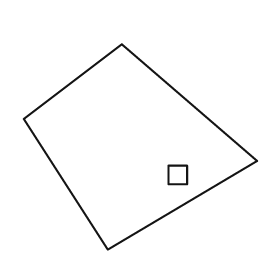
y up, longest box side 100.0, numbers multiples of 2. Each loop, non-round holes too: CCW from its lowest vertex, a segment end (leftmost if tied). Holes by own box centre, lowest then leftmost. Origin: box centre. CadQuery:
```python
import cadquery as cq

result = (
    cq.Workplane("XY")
    .moveTo(-14.0, -44.0)
    .lineTo(50.0, -6.0)
    .lineTo(-8.0, 44.0)
    .lineTo(-50.0, 12.0)
    .close()
    .moveTo(12.0, -16.0)
    .lineTo(20.0, -16.0)
    .lineTo(20.0, -8.0)
    .lineTo(12.0, -8.0)
    .close()
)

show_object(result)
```